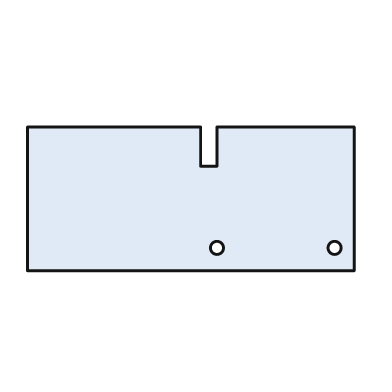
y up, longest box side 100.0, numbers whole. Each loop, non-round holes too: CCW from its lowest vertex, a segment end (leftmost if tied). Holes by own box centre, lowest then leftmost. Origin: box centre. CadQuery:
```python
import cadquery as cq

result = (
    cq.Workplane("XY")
    .moveTo(-50.0, -22.0)
    .lineTo(50.0, -22.0)
    .lineTo(50.0, 22.0)
    .lineTo(8.0, 22.0)
    .lineTo(8.0, 10.0)
    .lineTo(3.0, 10.0)
    .lineTo(3.0, 22.0)
    .lineTo(-50.0, 22.0)
    .close()
    .moveTo(8.0, -15.0)
    .circle(2.0)
    .moveTo(44.0, -15.0)
    .circle(2.0)
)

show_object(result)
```